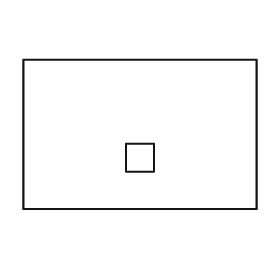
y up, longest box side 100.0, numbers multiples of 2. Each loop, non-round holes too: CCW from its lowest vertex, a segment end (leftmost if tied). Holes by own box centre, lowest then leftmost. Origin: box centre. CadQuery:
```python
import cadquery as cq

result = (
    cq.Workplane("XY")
    .moveTo(-50.0, -32.0)
    .lineTo(50.0, -32.0)
    .lineTo(50.0, 32.0)
    .lineTo(-50.0, 32.0)
    .close()
    .moveTo(-6.0, -16.0)
    .lineTo(6.0, -16.0)
    .lineTo(6.0, -4.0)
    .lineTo(-6.0, -4.0)
    .close()
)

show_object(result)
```